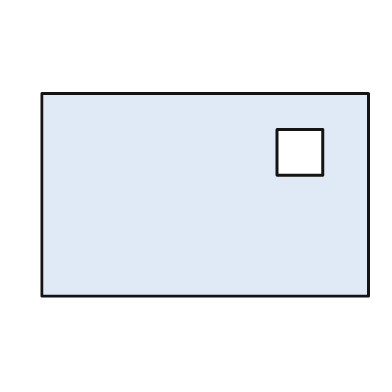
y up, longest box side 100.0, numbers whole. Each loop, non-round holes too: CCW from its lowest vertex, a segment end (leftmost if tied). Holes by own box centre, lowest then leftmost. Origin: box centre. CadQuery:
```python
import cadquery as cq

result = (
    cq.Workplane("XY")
    .moveTo(-50.0, -31.0)
    .lineTo(50.0, -31.0)
    .lineTo(50.0, 31.0)
    .lineTo(-50.0, 31.0)
    .close()
    .moveTo(22.0, 6.0)
    .lineTo(36.0, 6.0)
    .lineTo(36.0, 20.0)
    .lineTo(22.0, 20.0)
    .close()
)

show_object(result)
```